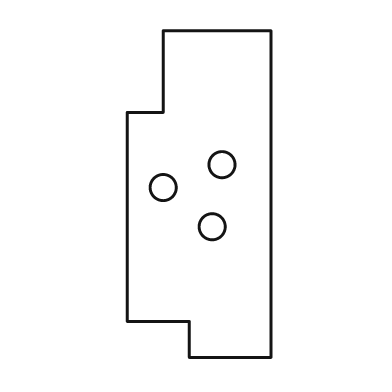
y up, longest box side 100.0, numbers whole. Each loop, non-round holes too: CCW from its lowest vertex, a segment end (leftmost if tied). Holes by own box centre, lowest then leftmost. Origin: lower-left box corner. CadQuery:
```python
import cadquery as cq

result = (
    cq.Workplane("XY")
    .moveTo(19.0, 0.0)
    .lineTo(44.0, 0.0)
    .lineTo(44.0, 100.0)
    .lineTo(11.0, 100.0)
    .lineTo(11.0, 75.0)
    .lineTo(0.0, 75.0)
    .lineTo(0.0, 11.0)
    .lineTo(19.0, 11.0)
    .close()
    .moveTo(26.0, 40.0)
    .circle(4.0)
    .moveTo(11.0, 52.0)
    .circle(4.0)
    .moveTo(29.0, 59.0)
    .circle(4.0)
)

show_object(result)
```